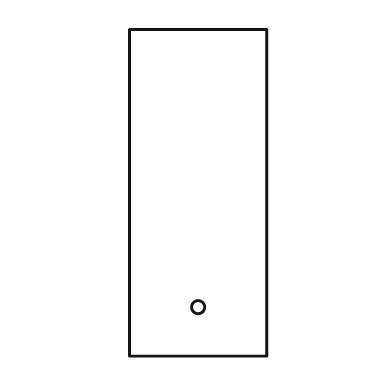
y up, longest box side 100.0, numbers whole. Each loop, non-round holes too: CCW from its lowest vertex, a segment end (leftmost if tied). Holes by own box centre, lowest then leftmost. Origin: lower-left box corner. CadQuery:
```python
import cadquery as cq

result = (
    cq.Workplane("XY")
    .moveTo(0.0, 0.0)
    .lineTo(42.0, 0.0)
    .lineTo(42.0, 100.0)
    .lineTo(0.0, 100.0)
    .close()
    .moveTo(21.0, 15.0)
    .circle(2.0)
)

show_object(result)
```